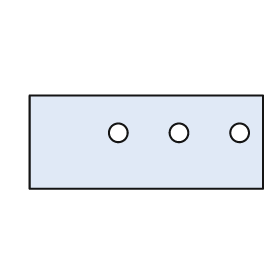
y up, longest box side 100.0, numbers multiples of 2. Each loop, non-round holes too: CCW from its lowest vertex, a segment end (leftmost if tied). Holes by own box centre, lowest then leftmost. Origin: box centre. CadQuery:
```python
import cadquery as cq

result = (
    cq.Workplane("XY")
    .moveTo(-50.0, -20.0)
    .lineTo(50.0, -20.0)
    .lineTo(50.0, 20.0)
    .lineTo(-50.0, 20.0)
    .close()
    .moveTo(-12.0, 4.0)
    .circle(4.0)
    .moveTo(14.0, 4.0)
    .circle(4.0)
    .moveTo(40.0, 4.0)
    .circle(4.0)
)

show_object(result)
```